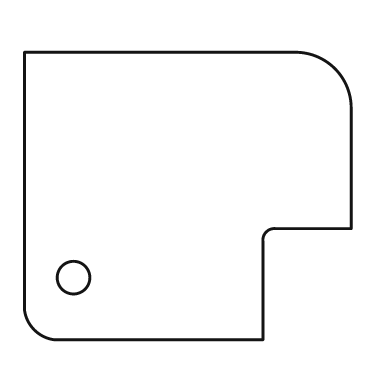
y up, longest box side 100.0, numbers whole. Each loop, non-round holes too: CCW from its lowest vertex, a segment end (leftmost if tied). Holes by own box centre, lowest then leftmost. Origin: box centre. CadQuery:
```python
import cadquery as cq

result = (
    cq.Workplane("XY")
    .moveTo(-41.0, -44.0)
    .lineTo(23.0, -44.0)
    .lineTo(23.0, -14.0)
    .threePointArc((24.0, -11.0), (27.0, -10.0))
    .lineTo(50.0, -10.0)
    .lineTo(50.0, 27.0)
    .threePointArc((45.0, 39.0), (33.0, 44.0))
    .lineTo(-50.0, 44.0)
    .lineTo(-50.0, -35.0)
    .threePointArc((-47.0, -41.0), (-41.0, -44.0))
    .close()
    .moveTo(-35.0, -25.0)
    .circle(5.0)
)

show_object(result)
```